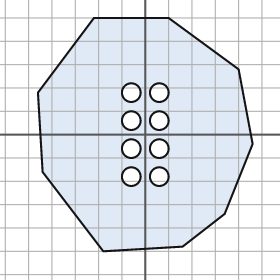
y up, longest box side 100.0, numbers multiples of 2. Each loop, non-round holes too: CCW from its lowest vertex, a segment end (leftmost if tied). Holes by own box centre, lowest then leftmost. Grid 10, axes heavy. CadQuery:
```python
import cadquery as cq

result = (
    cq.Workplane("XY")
    .moveTo(-18.0, -50.0)
    .lineTo(16.0, -48.0)
    .lineTo(34.0, -34.0)
    .lineTo(46.0, -4.0)
    .lineTo(40.0, 28.0)
    .lineTo(10.0, 50.0)
    .lineTo(-22.0, 50.0)
    .lineTo(-46.0, 18.0)
    .lineTo(-44.0, -16.0)
    .close()
    .moveTo(-6.0, -18.0)
    .circle(4.0)
    .moveTo(6.0, -18.0)
    .circle(4.0)
    .moveTo(-6.0, -6.0)
    .circle(4.0)
    .moveTo(6.0, -6.0)
    .circle(4.0)
    .moveTo(-6.0, 6.0)
    .circle(4.0)
    .moveTo(6.0, 6.0)
    .circle(4.0)
    .moveTo(-6.0, 18.0)
    .circle(4.0)
    .moveTo(6.0, 18.0)
    .circle(4.0)
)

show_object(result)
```